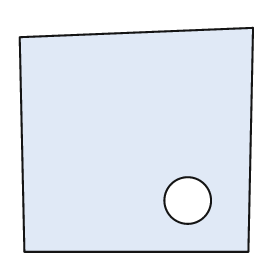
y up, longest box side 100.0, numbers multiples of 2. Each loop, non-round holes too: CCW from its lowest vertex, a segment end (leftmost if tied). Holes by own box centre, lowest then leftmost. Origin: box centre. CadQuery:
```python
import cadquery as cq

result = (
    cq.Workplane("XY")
    .moveTo(-48.0, -48.0)
    .lineTo(48.0, -48.0)
    .lineTo(50.0, 48.0)
    .lineTo(-50.0, 44.0)
    .close()
    .moveTo(22.0, -26.0)
    .circle(10.0)
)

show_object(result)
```